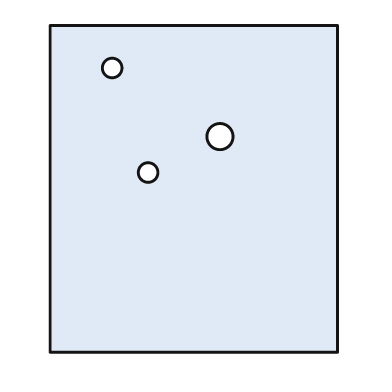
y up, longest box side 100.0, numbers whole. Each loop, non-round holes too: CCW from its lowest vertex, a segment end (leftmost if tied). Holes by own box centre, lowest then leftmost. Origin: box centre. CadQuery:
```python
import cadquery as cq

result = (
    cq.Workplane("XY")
    .moveTo(-44.0, -50.0)
    .lineTo(44.0, -50.0)
    .lineTo(44.0, 50.0)
    .lineTo(-44.0, 50.0)
    .close()
    .moveTo(-14.0, 5.0)
    .circle(3.0)
    .moveTo(8.0, 16.0)
    .circle(4.0)
    .moveTo(-25.0, 37.0)
    .circle(3.0)
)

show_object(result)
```